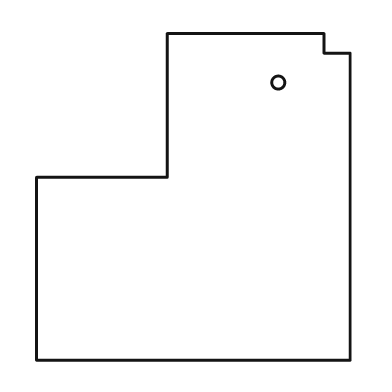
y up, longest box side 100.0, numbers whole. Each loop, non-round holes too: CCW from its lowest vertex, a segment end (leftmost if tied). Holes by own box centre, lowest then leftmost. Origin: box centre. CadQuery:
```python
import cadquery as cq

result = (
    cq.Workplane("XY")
    .moveTo(-48.0, -50.0)
    .lineTo(48.0, -50.0)
    .lineTo(48.0, 44.0)
    .lineTo(40.0, 44.0)
    .lineTo(40.0, 50.0)
    .lineTo(-8.0, 50.0)
    .lineTo(-8.0, 6.0)
    .lineTo(-48.0, 6.0)
    .close()
    .moveTo(26.0, 35.0)
    .circle(2.0)
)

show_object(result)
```